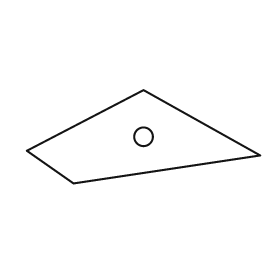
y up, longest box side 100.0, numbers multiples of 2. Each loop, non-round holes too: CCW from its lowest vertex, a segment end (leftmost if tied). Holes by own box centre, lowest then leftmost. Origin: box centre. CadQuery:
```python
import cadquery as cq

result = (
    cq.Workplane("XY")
    .moveTo(-30.0, -20.0)
    .lineTo(50.0, -8.0)
    .lineTo(0.0, 20.0)
    .lineTo(-50.0, -6.0)
    .close()
    .moveTo(0.0, 0.0)
    .circle(4.0)
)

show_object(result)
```